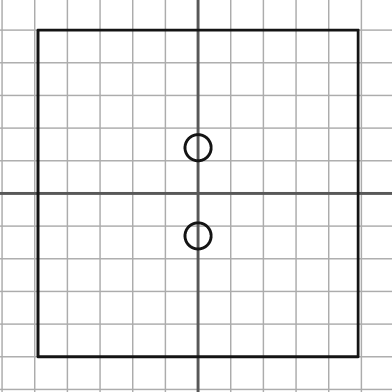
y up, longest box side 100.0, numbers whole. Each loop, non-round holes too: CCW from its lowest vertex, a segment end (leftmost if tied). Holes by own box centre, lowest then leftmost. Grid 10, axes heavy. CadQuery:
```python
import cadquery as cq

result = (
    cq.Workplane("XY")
    .moveTo(-49.0, -50.0)
    .lineTo(49.0, -50.0)
    .lineTo(49.0, 50.0)
    .lineTo(-49.0, 50.0)
    .close()
    .moveTo(0.0, -13.0)
    .circle(4.0)
    .moveTo(0.0, 14.0)
    .circle(4.0)
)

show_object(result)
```